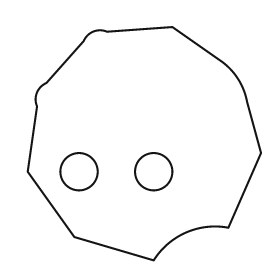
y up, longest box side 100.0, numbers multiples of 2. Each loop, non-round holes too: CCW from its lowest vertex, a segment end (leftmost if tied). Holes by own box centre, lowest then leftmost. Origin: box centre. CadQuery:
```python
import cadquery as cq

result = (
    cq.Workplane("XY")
    .moveTo(4.0, -50.0)
    .threePointArc((18.0, -38.0), (36.0, -36.0))
    .lineTo(50.0, -4.0)
    .lineTo(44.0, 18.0)
    .threePointArc((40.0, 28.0), (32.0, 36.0))
    .lineTo(12.0, 50.0)
    .lineTo(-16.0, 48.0)
    .threePointArc((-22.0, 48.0), (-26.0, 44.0))
    .lineTo(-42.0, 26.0)
    .threePointArc((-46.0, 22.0), (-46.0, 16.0))
    .lineTo(-50.0, -12.0)
    .lineTo(-30.0, -40.0)
    .close()
    .moveTo(-28.0, -12.0)
    .circle(8.0)
    .moveTo(4.0, -12.0)
    .circle(8.0)
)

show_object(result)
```